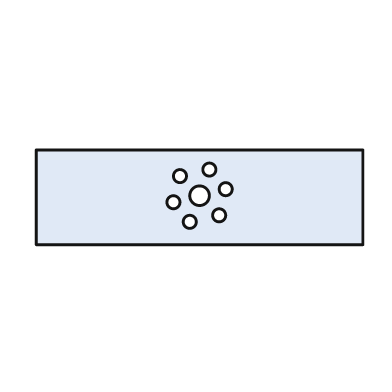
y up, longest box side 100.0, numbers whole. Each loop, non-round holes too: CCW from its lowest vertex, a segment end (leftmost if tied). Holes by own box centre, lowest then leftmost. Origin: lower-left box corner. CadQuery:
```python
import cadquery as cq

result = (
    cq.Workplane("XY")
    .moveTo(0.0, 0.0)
    .lineTo(100.0, 0.0)
    .lineTo(100.0, 29.0)
    .lineTo(0.0, 29.0)
    .close()
    .moveTo(47.0, 7.0)
    .circle(2.0)
    .moveTo(56.0, 9.0)
    .circle(2.0)
    .moveTo(42.0, 13.0)
    .circle(2.0)
    .moveTo(50.0, 15.0)
    .circle(3.0)
    .moveTo(58.0, 17.0)
    .circle(2.0)
    .moveTo(44.0, 21.0)
    .circle(2.0)
    .moveTo(53.0, 23.0)
    .circle(2.0)
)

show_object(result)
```